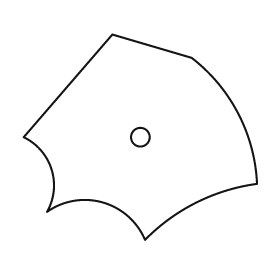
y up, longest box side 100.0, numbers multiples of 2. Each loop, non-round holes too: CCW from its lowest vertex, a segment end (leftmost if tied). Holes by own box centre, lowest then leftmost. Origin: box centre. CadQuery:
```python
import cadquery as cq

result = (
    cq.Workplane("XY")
    .moveTo(2.0, -44.0)
    .threePointArc((24.0, -28.0), (50.0, -20.0))
    .threePointArc((42.0, 10.0), (22.0, 34.0))
    .lineTo(-12.0, 44.0)
    .lineTo(-50.0, 0.0)
    .threePointArc((-38.0, -14.0), (-40.0, -32.0))
    .threePointArc((-16.0, -28.0), (2.0, -44.0))
    .close()
    .moveTo(0.0, 0.0)
    .circle(4.0)
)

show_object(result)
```